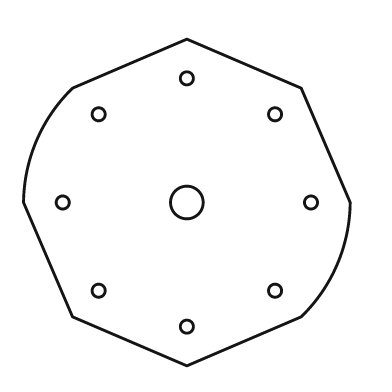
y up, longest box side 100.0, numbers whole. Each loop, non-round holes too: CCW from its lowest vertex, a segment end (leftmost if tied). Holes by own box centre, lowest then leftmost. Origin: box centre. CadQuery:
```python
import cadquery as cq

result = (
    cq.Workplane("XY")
    .moveTo(0.0, -50.0)
    .lineTo(35.0, -35.0)
    .threePointArc((46.0, -19.0), (50.0, 0.0))
    .lineTo(35.0, 35.0)
    .lineTo(0.0, 50.0)
    .lineTo(-35.0, 35.0)
    .threePointArc((-46.0, 19.0), (-50.0, 0.0))
    .lineTo(-35.0, -35.0)
    .close()
    .moveTo(0.0, -38.0)
    .circle(2.0)
    .moveTo(-27.0, -27.0)
    .circle(2.0)
    .moveTo(27.0, -27.0)
    .circle(2.0)
    .moveTo(-38.0, 0.0)
    .circle(2.0)
    .moveTo(0.0, 0.0)
    .circle(5.0)
    .moveTo(38.0, 0.0)
    .circle(2.0)
    .moveTo(-27.0, 27.0)
    .circle(2.0)
    .moveTo(27.0, 27.0)
    .circle(2.0)
    .moveTo(0.0, 38.0)
    .circle(2.0)
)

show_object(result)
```